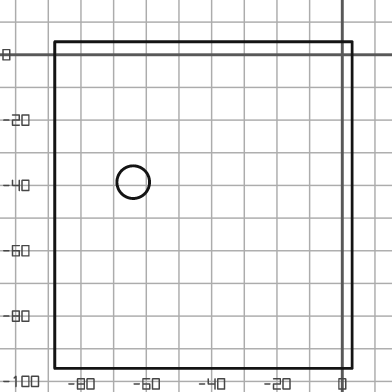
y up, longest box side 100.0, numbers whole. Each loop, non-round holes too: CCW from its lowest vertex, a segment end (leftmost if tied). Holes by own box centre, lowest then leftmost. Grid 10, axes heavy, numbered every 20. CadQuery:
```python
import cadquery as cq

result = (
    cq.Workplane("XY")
    .moveTo(-88.0, -96.0)
    .lineTo(3.0, -96.0)
    .lineTo(3.0, 4.0)
    .lineTo(-88.0, 4.0)
    .close()
    .moveTo(-64.0, -39.0)
    .circle(5.0)
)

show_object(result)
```